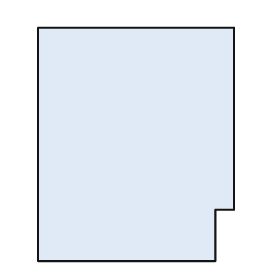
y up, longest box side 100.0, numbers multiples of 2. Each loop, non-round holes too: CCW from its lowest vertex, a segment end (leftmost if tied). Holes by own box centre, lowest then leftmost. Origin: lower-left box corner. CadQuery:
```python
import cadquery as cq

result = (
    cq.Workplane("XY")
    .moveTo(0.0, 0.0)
    .lineTo(76.0, 0.0)
    .lineTo(76.0, 22.0)
    .lineTo(84.0, 22.0)
    .lineTo(84.0, 100.0)
    .lineTo(0.0, 100.0)
    .close()
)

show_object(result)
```